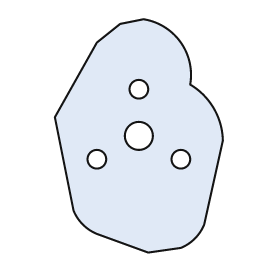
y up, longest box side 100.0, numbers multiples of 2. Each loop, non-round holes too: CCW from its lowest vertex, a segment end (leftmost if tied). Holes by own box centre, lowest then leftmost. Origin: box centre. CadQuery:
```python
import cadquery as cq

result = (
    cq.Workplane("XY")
    .moveTo(4.0, -50.0)
    .lineTo(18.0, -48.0)
    .threePointArc((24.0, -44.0), (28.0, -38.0))
    .lineTo(36.0, -2.0)
    .threePointArc((32.0, 12.0), (22.0, 22.0))
    .threePointArc((18.0, 40.0), (2.0, 50.0))
    .lineTo(-8.0, 48.0)
    .lineTo(-18.0, 40.0)
    .lineTo(-36.0, 8.0)
    .lineTo(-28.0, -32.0)
    .threePointArc((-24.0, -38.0), (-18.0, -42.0))
    .close()
    .moveTo(-18.0, -10.0)
    .circle(4.0)
    .moveTo(18.0, -10.0)
    .circle(4.0)
    .moveTo(0.0, 0.0)
    .circle(6.0)
    .moveTo(0.0, 20.0)
    .circle(4.0)
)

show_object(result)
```